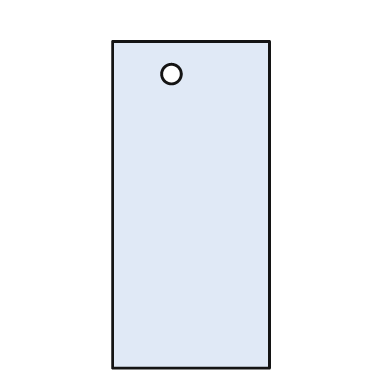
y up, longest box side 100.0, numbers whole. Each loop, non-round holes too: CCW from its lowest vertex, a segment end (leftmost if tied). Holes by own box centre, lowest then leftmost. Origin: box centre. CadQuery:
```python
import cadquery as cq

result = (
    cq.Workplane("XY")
    .moveTo(-24.0, -50.0)
    .lineTo(24.0, -50.0)
    .lineTo(24.0, 50.0)
    .lineTo(-24.0, 50.0)
    .close()
    .moveTo(-6.0, 40.0)
    .circle(3.0)
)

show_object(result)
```